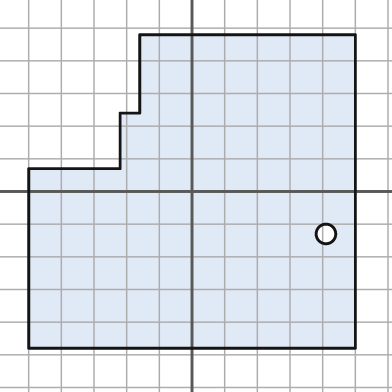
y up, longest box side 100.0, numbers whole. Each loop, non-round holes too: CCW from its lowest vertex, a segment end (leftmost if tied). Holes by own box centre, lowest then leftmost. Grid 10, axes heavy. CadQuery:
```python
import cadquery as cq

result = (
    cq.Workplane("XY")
    .moveTo(-50.0, -48.0)
    .lineTo(50.0, -48.0)
    .lineTo(50.0, 48.0)
    .lineTo(-16.0, 48.0)
    .lineTo(-16.0, 24.0)
    .lineTo(-22.0, 24.0)
    .lineTo(-22.0, 7.0)
    .lineTo(-50.0, 7.0)
    .close()
    .moveTo(41.0, -13.0)
    .circle(3.0)
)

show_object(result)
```